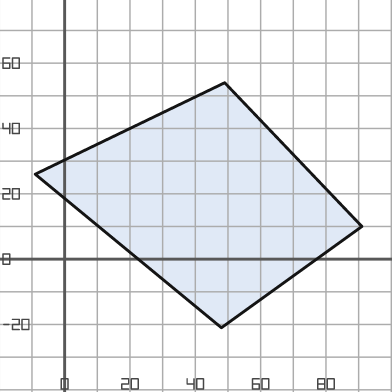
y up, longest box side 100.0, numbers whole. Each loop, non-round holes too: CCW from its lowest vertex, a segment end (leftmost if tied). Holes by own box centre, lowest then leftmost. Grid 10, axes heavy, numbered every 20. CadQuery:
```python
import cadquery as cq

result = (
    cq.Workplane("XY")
    .moveTo(48.0, -21.0)
    .lineTo(91.0, 10.0)
    .lineTo(49.0, 54.0)
    .lineTo(-9.0, 26.0)
    .close()
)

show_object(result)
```